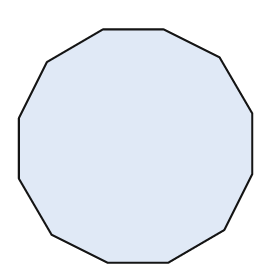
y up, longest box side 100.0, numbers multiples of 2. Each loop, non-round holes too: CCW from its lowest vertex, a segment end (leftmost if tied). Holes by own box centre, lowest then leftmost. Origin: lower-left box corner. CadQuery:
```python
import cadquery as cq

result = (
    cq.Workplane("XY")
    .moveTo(38.0, 0.0)
    .lineTo(64.0, 0.0)
    .lineTo(88.0, 14.0)
    .lineTo(100.0, 38.0)
    .lineTo(100.0, 64.0)
    .lineTo(86.0, 88.0)
    .lineTo(62.0, 100.0)
    .lineTo(36.0, 100.0)
    .lineTo(12.0, 86.0)
    .lineTo(0.0, 62.0)
    .lineTo(0.0, 36.0)
    .lineTo(14.0, 12.0)
    .close()
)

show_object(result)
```